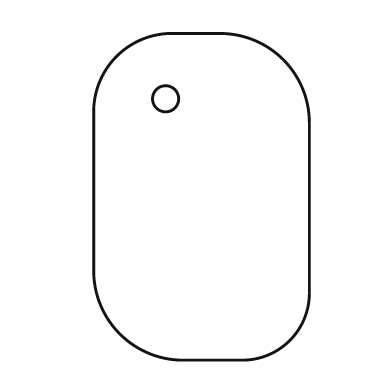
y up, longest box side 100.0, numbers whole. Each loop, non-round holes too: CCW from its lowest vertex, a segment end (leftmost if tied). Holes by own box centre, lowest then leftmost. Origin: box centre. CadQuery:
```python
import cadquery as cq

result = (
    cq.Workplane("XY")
    .moveTo(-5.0, -50.0)
    .lineTo(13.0, -50.0)
    .threePointArc((27.0, -44.0), (33.0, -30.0))
    .lineTo(33.0, 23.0)
    .threePointArc((25.0, 42.0), (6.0, 50.0))
    .lineTo(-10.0, 50.0)
    .threePointArc((-26.0, 43.0), (-33.0, 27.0))
    .lineTo(-33.0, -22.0)
    .threePointArc((-25.0, -42.0), (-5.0, -50.0))
    .close()
    .moveTo(-11.0, 30.0)
    .circle(4.0)
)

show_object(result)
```